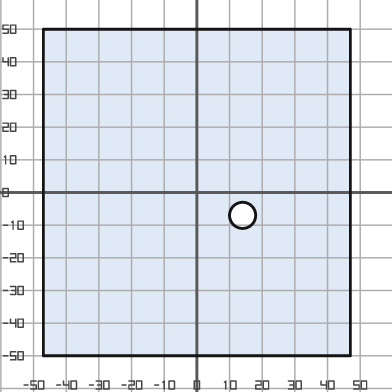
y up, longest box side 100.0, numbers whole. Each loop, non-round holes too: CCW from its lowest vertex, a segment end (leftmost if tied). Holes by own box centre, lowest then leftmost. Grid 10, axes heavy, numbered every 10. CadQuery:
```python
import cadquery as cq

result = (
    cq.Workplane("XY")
    .moveTo(-47.0, -50.0)
    .lineTo(47.0, -50.0)
    .lineTo(47.0, 50.0)
    .lineTo(-47.0, 50.0)
    .close()
    .moveTo(14.0, -7.0)
    .circle(4.0)
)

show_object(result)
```